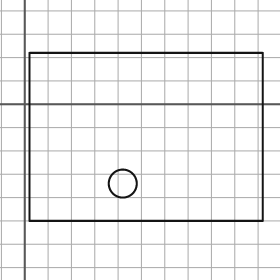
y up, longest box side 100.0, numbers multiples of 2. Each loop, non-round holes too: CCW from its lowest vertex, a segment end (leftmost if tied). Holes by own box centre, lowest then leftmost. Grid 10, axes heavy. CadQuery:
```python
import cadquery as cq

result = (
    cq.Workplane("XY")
    .moveTo(2.0, -50.0)
    .lineTo(102.0, -50.0)
    .lineTo(102.0, 22.0)
    .lineTo(2.0, 22.0)
    .close()
    .moveTo(42.0, -34.0)
    .circle(6.0)
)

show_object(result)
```